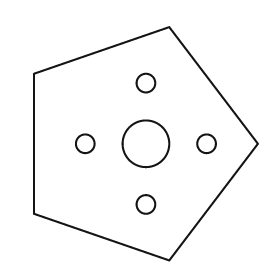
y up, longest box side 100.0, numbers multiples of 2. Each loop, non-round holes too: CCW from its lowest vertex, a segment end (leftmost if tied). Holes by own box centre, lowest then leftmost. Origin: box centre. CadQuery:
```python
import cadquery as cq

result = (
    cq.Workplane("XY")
    .moveTo(10.0, -50.0)
    .lineTo(48.0, 0.0)
    .lineTo(10.0, 50.0)
    .lineTo(-48.0, 30.0)
    .lineTo(-48.0, -30.0)
    .close()
    .moveTo(0.0, -26.0)
    .circle(4.0)
    .moveTo(-26.0, 0.0)
    .circle(4.0)
    .moveTo(0.0, 0.0)
    .circle(10.0)
    .moveTo(26.0, 0.0)
    .circle(4.0)
    .moveTo(0.0, 26.0)
    .circle(4.0)
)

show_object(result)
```